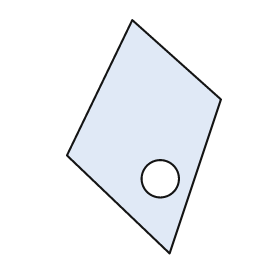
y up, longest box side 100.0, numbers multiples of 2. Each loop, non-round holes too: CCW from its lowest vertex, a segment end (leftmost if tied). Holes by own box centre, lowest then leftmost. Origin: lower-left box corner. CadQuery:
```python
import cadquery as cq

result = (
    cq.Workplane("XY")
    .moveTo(44.0, 0.0)
    .lineTo(66.0, 66.0)
    .lineTo(28.0, 100.0)
    .lineTo(0.0, 42.0)
    .close()
    .moveTo(40.0, 32.0)
    .circle(8.0)
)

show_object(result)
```